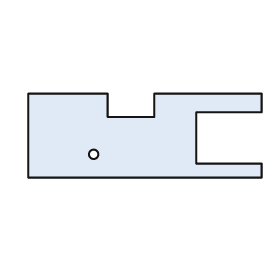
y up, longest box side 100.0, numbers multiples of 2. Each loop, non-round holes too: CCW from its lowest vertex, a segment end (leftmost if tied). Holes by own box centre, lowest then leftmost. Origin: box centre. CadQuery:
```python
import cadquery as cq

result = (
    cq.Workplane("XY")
    .moveTo(-50.0, -18.0)
    .lineTo(50.0, -18.0)
    .lineTo(50.0, -12.0)
    .lineTo(22.0, -12.0)
    .lineTo(22.0, 10.0)
    .lineTo(50.0, 10.0)
    .lineTo(50.0, 18.0)
    .lineTo(4.0, 18.0)
    .lineTo(4.0, 8.0)
    .lineTo(-16.0, 8.0)
    .lineTo(-16.0, 18.0)
    .lineTo(-50.0, 18.0)
    .close()
    .moveTo(-22.0, -8.0)
    .circle(2.0)
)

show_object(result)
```